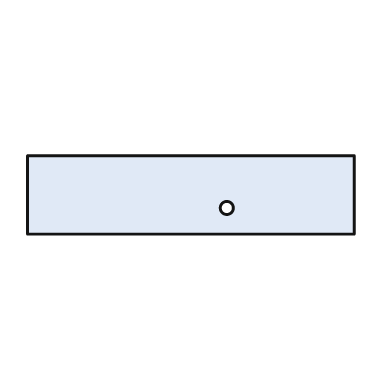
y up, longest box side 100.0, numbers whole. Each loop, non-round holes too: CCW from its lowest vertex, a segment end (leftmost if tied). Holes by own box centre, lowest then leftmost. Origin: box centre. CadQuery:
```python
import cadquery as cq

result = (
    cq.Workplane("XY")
    .moveTo(-50.0, -12.0)
    .lineTo(50.0, -12.0)
    .lineTo(50.0, 12.0)
    .lineTo(-50.0, 12.0)
    .close()
    .moveTo(11.0, -4.0)
    .circle(2.0)
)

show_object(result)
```